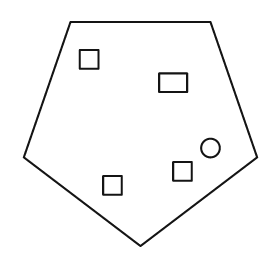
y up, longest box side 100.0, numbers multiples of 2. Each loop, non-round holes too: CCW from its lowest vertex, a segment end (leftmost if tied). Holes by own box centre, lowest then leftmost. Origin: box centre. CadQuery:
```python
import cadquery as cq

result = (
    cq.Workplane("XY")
    .moveTo(0.0, -48.0)
    .lineTo(50.0, -10.0)
    .lineTo(30.0, 48.0)
    .lineTo(-30.0, 48.0)
    .lineTo(-50.0, -10.0)
    .close()
    .moveTo(-16.0, -26.0)
    .lineTo(-8.0, -26.0)
    .lineTo(-8.0, -18.0)
    .lineTo(-16.0, -18.0)
    .close()
    .moveTo(14.0, -20.0)
    .lineTo(22.0, -20.0)
    .lineTo(22.0, -12.0)
    .lineTo(14.0, -12.0)
    .close()
    .moveTo(30.0, -6.0)
    .circle(4.0)
    .moveTo(8.0, 18.0)
    .lineTo(20.0, 18.0)
    .lineTo(20.0, 26.0)
    .lineTo(8.0, 26.0)
    .close()
    .moveTo(-26.0, 28.0)
    .lineTo(-18.0, 28.0)
    .lineTo(-18.0, 36.0)
    .lineTo(-26.0, 36.0)
    .close()
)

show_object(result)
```